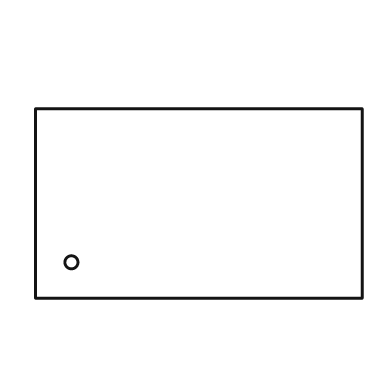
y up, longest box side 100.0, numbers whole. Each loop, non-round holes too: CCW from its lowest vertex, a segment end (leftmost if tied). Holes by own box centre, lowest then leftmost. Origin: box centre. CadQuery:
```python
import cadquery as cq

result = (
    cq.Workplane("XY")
    .moveTo(-50.0, -29.0)
    .lineTo(50.0, -29.0)
    .lineTo(50.0, 29.0)
    .lineTo(-50.0, 29.0)
    .close()
    .moveTo(-39.0, -18.0)
    .circle(2.0)
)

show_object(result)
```